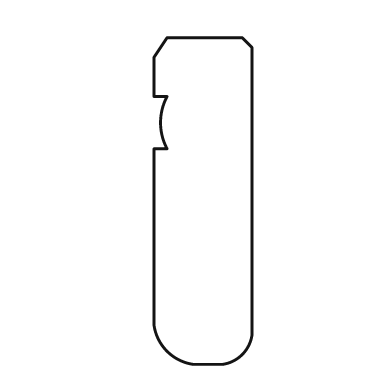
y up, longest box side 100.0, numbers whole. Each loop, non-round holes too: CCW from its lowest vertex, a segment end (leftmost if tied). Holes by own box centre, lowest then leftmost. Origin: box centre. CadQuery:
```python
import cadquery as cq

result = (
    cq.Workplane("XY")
    .moveTo(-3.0, -50.0)
    .lineTo(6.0, -50.0)
    .threePointArc((12.0, -47.0), (15.0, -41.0))
    .lineTo(15.0, 47.0)
    .lineTo(12.0, 50.0)
    .lineTo(-11.0, 50.0)
    .lineTo(-15.0, 44.0)
    .lineTo(-15.0, 32.0)
    .lineTo(-11.0, 32.0)
    .threePointArc((-13.0, 24.0), (-11.0, 16.0))
    .lineTo(-15.0, 16.0)
    .lineTo(-15.0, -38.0)
    .threePointArc((-11.0, -46.0), (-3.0, -50.0))
    .close()
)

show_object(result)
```